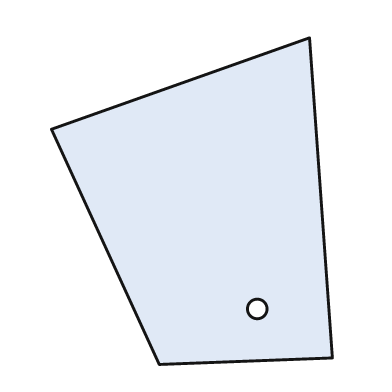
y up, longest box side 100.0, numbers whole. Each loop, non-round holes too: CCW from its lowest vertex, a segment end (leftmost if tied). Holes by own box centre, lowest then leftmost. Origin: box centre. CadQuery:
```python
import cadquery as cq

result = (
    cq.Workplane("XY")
    .moveTo(-10.0, -50.0)
    .lineTo(43.0, -48.0)
    .lineTo(36.0, 50.0)
    .lineTo(-43.0, 22.0)
    .close()
    .moveTo(20.0, -33.0)
    .circle(3.0)
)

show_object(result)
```